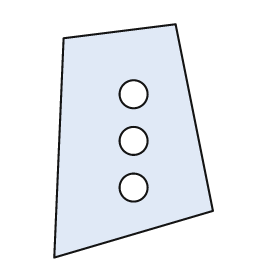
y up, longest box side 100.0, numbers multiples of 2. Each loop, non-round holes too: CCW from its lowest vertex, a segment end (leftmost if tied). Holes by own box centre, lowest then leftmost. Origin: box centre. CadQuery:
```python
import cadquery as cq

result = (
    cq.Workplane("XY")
    .moveTo(-34.0, -50.0)
    .lineTo(34.0, -30.0)
    .lineTo(18.0, 50.0)
    .lineTo(-30.0, 44.0)
    .close()
    .moveTo(0.0, -20.0)
    .circle(6.0)
    .moveTo(0.0, 0.0)
    .circle(6.0)
    .moveTo(0.0, 20.0)
    .circle(6.0)
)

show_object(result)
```